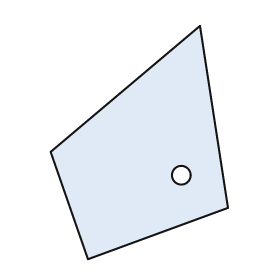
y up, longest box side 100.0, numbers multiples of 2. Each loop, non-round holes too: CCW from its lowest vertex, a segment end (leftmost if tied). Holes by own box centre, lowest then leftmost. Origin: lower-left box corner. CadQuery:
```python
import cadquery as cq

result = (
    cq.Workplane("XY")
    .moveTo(16.0, 0.0)
    .lineTo(76.0, 22.0)
    .lineTo(64.0, 100.0)
    .lineTo(0.0, 46.0)
    .close()
    .moveTo(56.0, 36.0)
    .circle(4.0)
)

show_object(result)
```